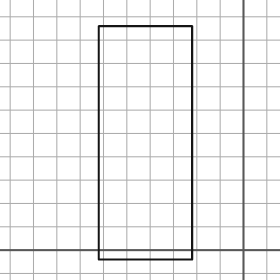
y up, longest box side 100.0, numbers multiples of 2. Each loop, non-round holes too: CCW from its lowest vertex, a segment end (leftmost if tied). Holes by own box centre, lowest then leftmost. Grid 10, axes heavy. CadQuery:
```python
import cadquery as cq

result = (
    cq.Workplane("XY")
    .moveTo(-62.0, -4.0)
    .lineTo(-22.0, -4.0)
    .lineTo(-22.0, 96.0)
    .lineTo(-62.0, 96.0)
    .close()
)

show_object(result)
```